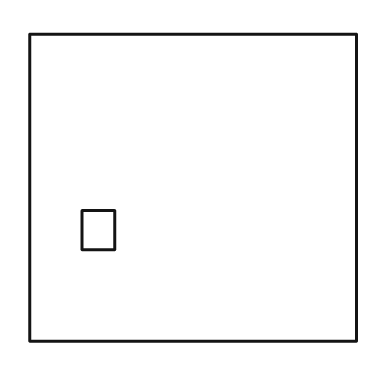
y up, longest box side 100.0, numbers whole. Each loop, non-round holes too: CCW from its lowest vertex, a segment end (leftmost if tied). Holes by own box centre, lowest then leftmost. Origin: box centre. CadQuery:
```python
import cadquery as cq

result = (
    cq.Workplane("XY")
    .moveTo(-50.0, -47.0)
    .lineTo(50.0, -47.0)
    .lineTo(50.0, 47.0)
    .lineTo(-50.0, 47.0)
    .close()
    .moveTo(-34.0, -19.0)
    .lineTo(-24.0, -19.0)
    .lineTo(-24.0, -7.0)
    .lineTo(-34.0, -7.0)
    .close()
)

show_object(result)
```